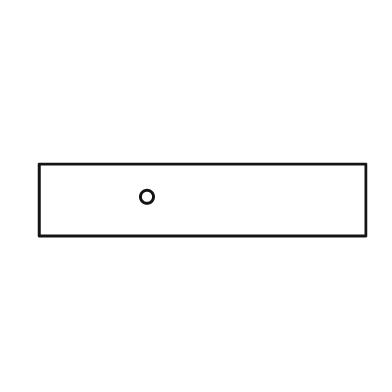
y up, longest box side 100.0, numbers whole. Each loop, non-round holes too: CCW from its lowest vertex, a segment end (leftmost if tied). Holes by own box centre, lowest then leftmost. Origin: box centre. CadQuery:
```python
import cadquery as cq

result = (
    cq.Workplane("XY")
    .moveTo(-50.0, -11.0)
    .lineTo(50.0, -11.0)
    .lineTo(50.0, 11.0)
    .lineTo(-50.0, 11.0)
    .close()
    .moveTo(-17.0, 1.0)
    .circle(2.0)
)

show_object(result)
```